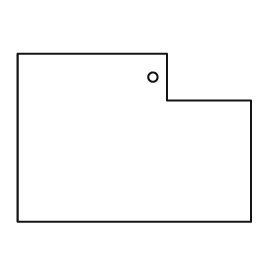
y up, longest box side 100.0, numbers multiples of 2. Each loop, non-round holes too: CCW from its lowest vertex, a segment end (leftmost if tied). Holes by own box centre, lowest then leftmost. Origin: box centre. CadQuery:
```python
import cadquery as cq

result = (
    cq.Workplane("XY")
    .moveTo(-50.0, -36.0)
    .lineTo(50.0, -36.0)
    .lineTo(50.0, 16.0)
    .lineTo(14.0, 16.0)
    .lineTo(14.0, 36.0)
    .lineTo(-50.0, 36.0)
    .close()
    .moveTo(8.0, 26.0)
    .circle(2.0)
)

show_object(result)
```